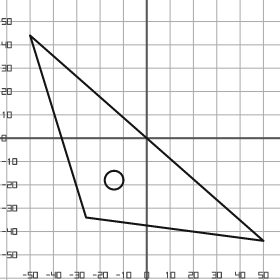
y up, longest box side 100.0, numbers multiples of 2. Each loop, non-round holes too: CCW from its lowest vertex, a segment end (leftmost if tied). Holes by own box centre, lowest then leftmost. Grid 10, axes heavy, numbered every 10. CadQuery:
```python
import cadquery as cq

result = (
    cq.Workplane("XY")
    .moveTo(50.0, -44.0)
    .lineTo(-50.0, 44.0)
    .lineTo(-26.0, -34.0)
    .close()
    .moveTo(-14.0, -18.0)
    .circle(4.0)
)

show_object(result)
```